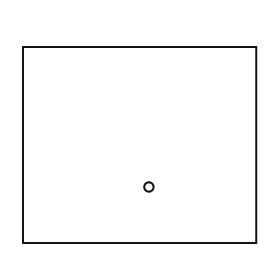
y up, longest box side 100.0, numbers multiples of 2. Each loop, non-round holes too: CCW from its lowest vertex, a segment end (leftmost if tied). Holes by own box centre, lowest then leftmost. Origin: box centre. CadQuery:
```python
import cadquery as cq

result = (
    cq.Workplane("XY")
    .moveTo(-50.0, -42.0)
    .lineTo(50.0, -42.0)
    .lineTo(50.0, 42.0)
    .lineTo(-50.0, 42.0)
    .close()
    .moveTo(4.0, -18.0)
    .circle(2.0)
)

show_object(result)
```